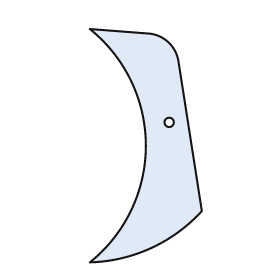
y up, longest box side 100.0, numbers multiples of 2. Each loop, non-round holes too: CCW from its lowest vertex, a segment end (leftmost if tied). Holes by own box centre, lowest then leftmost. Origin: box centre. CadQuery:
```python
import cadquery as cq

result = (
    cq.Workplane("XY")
    .moveTo(-24.0, -50.0)
    .threePointArc((2.0, -44.0), (24.0, -28.0))
    .lineTo(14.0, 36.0)
    .threePointArc((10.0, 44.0), (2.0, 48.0))
    .lineTo(-24.0, 50.0)
    .threePointArc((0.0, 0.0), (-24.0, -50.0))
    .close()
    .moveTo(10.0, 10.0)
    .circle(2.0)
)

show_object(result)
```